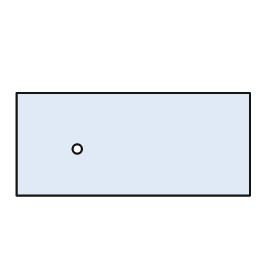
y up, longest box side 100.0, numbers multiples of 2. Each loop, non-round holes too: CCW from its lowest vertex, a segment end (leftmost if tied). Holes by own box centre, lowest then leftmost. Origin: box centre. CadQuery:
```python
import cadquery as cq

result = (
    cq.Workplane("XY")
    .moveTo(-50.0, -22.0)
    .lineTo(50.0, -22.0)
    .lineTo(50.0, 22.0)
    .lineTo(-50.0, 22.0)
    .close()
    .moveTo(-24.0, -2.0)
    .circle(2.0)
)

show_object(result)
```